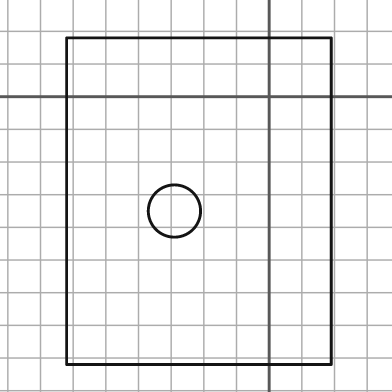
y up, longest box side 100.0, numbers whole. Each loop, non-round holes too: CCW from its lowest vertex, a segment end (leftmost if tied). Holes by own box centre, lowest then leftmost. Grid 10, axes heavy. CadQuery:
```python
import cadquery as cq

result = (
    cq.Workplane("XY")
    .moveTo(-62.0, -82.0)
    .lineTo(19.0, -82.0)
    .lineTo(19.0, 18.0)
    .lineTo(-62.0, 18.0)
    .close()
    .moveTo(-29.0, -35.0)
    .circle(8.0)
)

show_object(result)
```